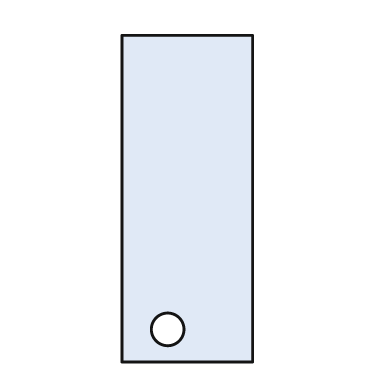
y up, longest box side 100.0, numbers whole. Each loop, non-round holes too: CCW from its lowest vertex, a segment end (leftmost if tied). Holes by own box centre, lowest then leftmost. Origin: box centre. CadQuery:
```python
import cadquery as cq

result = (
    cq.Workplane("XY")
    .moveTo(-20.0, -50.0)
    .lineTo(20.0, -50.0)
    .lineTo(20.0, 50.0)
    .lineTo(-20.0, 50.0)
    .close()
    .moveTo(-6.0, -40.0)
    .circle(5.0)
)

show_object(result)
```